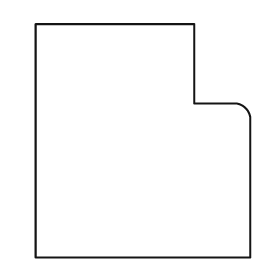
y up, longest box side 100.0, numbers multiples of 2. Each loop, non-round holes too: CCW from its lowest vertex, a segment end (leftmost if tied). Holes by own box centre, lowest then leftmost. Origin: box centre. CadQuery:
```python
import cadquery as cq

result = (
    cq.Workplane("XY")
    .moveTo(-46.0, -50.0)
    .lineTo(46.0, -50.0)
    .lineTo(46.0, 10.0)
    .threePointArc((44.0, 14.0), (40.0, 16.0))
    .lineTo(22.0, 16.0)
    .lineTo(22.0, 50.0)
    .lineTo(-46.0, 50.0)
    .close()
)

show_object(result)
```